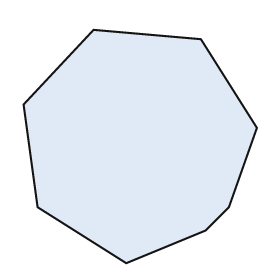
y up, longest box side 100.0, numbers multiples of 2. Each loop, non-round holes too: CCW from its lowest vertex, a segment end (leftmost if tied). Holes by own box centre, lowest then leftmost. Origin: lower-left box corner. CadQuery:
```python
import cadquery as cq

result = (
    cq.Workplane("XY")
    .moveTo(44.0, 0.0)
    .lineTo(78.0, 14.0)
    .lineTo(88.0, 24.0)
    .lineTo(100.0, 58.0)
    .lineTo(76.0, 96.0)
    .lineTo(30.0, 100.0)
    .lineTo(0.0, 68.0)
    .lineTo(6.0, 24.0)
    .close()
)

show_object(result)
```